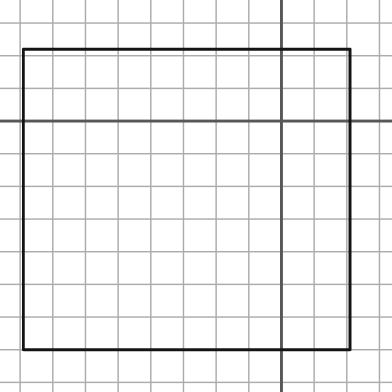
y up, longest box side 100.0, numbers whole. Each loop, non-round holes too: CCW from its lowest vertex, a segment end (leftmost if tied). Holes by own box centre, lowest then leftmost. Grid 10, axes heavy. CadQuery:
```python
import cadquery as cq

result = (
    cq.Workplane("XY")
    .moveTo(-79.0, -70.0)
    .lineTo(21.0, -70.0)
    .lineTo(21.0, 22.0)
    .lineTo(-79.0, 22.0)
    .close()
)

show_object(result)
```